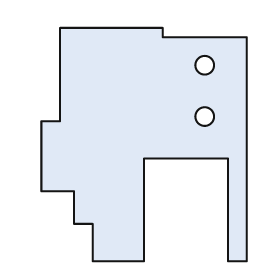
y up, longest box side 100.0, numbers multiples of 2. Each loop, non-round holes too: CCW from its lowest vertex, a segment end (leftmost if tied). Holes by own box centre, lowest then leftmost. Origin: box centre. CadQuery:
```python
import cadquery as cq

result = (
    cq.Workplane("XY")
    .moveTo(-22.0, -50.0)
    .lineTo(0.0, -50.0)
    .lineTo(0.0, -6.0)
    .lineTo(36.0, -6.0)
    .lineTo(36.0, -50.0)
    .lineTo(44.0, -50.0)
    .lineTo(44.0, 46.0)
    .lineTo(8.0, 46.0)
    .lineTo(8.0, 50.0)
    .lineTo(-36.0, 50.0)
    .lineTo(-36.0, 10.0)
    .lineTo(-44.0, 10.0)
    .lineTo(-44.0, -20.0)
    .lineTo(-30.0, -20.0)
    .lineTo(-30.0, -34.0)
    .lineTo(-22.0, -34.0)
    .close()
    .moveTo(26.0, 12.0)
    .circle(4.0)
    .moveTo(26.0, 34.0)
    .circle(4.0)
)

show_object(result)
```